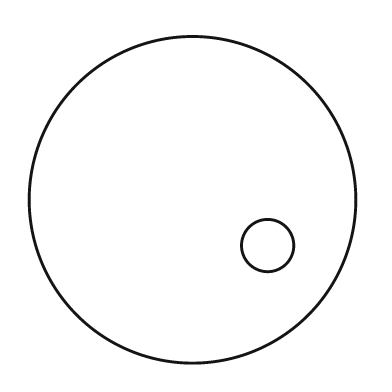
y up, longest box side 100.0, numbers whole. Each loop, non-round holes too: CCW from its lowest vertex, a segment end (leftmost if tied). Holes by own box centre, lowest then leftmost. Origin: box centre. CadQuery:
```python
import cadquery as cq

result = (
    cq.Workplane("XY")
    .moveTo(0.0, 0.0)
    .circle(50.0)
    .moveTo(23.0, -14.0)
    .circle(8.0)
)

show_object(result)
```